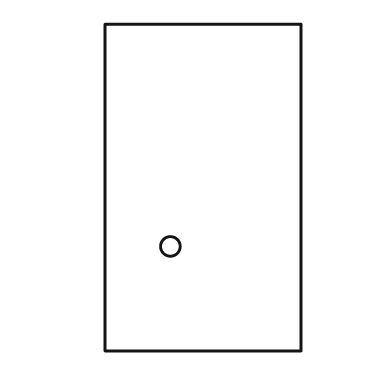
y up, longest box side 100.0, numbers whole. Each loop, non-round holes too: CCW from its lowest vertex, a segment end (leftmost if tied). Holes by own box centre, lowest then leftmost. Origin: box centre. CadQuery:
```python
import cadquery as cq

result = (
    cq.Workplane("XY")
    .moveTo(-30.0, -50.0)
    .lineTo(30.0, -50.0)
    .lineTo(30.0, 50.0)
    .lineTo(-30.0, 50.0)
    .close()
    .moveTo(-10.0, -18.0)
    .circle(3.0)
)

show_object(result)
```